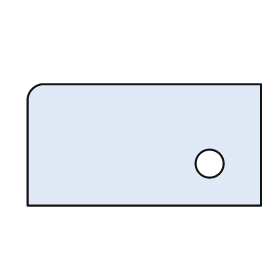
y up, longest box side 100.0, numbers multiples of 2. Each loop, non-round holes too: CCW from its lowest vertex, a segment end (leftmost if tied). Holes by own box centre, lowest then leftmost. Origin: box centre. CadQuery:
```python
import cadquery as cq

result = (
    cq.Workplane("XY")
    .moveTo(-50.0, -26.0)
    .lineTo(50.0, -26.0)
    .lineTo(50.0, 26.0)
    .lineTo(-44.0, 26.0)
    .threePointArc((-48.0, 24.0), (-50.0, 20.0))
    .close()
    .moveTo(28.0, -8.0)
    .circle(6.0)
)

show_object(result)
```